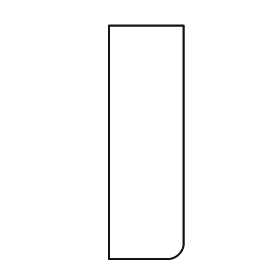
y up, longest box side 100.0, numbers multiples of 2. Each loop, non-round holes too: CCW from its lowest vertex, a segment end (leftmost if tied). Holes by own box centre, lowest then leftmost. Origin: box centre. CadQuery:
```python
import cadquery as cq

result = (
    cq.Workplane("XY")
    .moveTo(-16.0, -50.0)
    .lineTo(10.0, -50.0)
    .threePointArc((14.0, -48.0), (16.0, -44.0))
    .lineTo(16.0, 50.0)
    .lineTo(-16.0, 50.0)
    .close()
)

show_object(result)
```